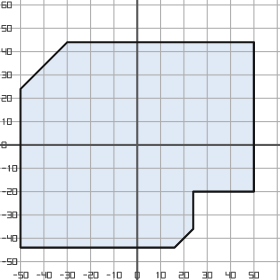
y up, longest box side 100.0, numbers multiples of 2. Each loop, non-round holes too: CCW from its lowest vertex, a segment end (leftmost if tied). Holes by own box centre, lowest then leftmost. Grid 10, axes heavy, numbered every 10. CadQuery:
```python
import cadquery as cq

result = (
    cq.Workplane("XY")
    .moveTo(-50.0, -44.0)
    .lineTo(16.0, -44.0)
    .lineTo(24.0, -36.0)
    .lineTo(24.0, -20.0)
    .lineTo(50.0, -20.0)
    .lineTo(50.0, 44.0)
    .lineTo(-30.0, 44.0)
    .lineTo(-50.0, 24.0)
    .close()
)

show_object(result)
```